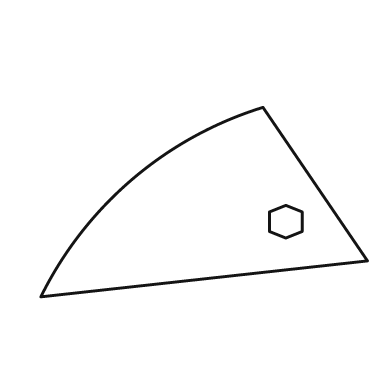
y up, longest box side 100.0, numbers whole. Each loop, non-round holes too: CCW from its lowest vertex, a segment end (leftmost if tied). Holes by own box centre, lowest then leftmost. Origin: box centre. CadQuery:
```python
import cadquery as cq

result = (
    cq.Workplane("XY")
    .moveTo(-50.0, -29.0)
    .lineTo(50.0, -18.0)
    .lineTo(18.0, 29.0)
    .threePointArc((-22.0, 7.0), (-50.0, -29.0))
    .close()
    .moveTo(25.0, -11.0)
    .lineTo(30.0, -9.0)
    .lineTo(30.0, -3.0)
    .lineTo(25.0, -1.0)
    .lineTo(20.0, -3.0)
    .lineTo(20.0, -9.0)
    .close()
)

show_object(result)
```